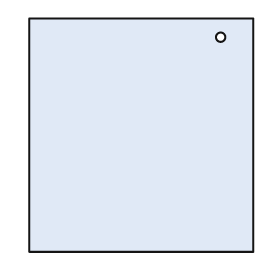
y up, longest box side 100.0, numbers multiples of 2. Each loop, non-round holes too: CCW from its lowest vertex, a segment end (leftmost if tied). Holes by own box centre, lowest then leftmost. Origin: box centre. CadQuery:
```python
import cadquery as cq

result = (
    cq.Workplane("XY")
    .moveTo(-48.0, -50.0)
    .lineTo(48.0, -50.0)
    .lineTo(48.0, 50.0)
    .lineTo(-48.0, 50.0)
    .close()
    .moveTo(34.0, 42.0)
    .circle(2.0)
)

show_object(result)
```